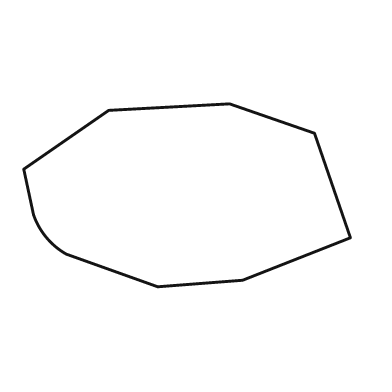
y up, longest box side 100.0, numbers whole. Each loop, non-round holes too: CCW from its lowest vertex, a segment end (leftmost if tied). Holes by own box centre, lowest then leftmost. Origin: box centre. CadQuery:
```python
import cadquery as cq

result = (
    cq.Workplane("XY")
    .moveTo(-9.0, -28.0)
    .lineTo(17.0, -26.0)
    .lineTo(50.0, -13.0)
    .lineTo(39.0, 19.0)
    .lineTo(13.0, 28.0)
    .lineTo(-24.0, 26.0)
    .lineTo(-50.0, 8.0)
    .lineTo(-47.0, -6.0)
    .threePointArc((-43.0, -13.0), (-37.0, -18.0))
    .close()
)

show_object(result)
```